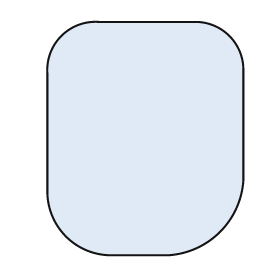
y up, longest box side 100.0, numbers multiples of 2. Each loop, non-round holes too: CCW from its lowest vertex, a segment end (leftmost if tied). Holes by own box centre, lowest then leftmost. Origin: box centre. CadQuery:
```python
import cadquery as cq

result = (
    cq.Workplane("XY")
    .moveTo(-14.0, -50.0)
    .lineTo(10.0, -50.0)
    .threePointArc((32.0, -40.0), (42.0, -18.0))
    .lineTo(42.0, 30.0)
    .threePointArc((36.0, 44.0), (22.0, 50.0))
    .lineTo(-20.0, 50.0)
    .threePointArc((-36.0, 44.0), (-42.0, 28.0))
    .lineTo(-42.0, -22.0)
    .threePointArc((-34.0, -42.0), (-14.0, -50.0))
    .close()
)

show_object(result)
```